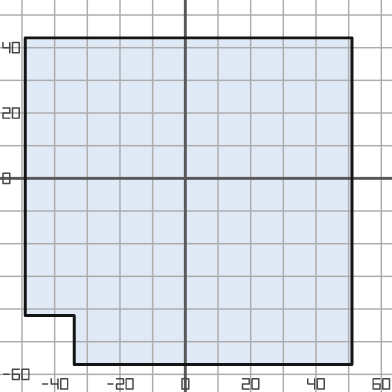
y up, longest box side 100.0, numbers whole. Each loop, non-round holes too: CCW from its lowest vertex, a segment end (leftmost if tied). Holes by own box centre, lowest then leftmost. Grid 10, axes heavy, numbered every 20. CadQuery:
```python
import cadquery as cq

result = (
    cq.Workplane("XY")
    .moveTo(-34.0, -57.0)
    .lineTo(51.0, -57.0)
    .lineTo(51.0, 43.0)
    .lineTo(-49.0, 43.0)
    .lineTo(-49.0, -42.0)
    .lineTo(-34.0, -42.0)
    .close()
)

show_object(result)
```